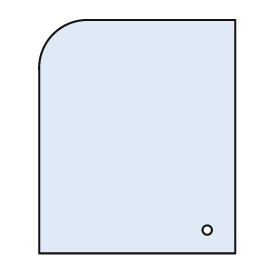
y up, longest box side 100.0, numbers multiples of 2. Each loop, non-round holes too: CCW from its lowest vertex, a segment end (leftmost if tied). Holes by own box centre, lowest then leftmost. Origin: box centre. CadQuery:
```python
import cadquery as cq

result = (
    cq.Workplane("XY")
    .moveTo(-42.0, -50.0)
    .lineTo(42.0, -50.0)
    .lineTo(42.0, 50.0)
    .lineTo(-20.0, 50.0)
    .threePointArc((-36.0, 44.0), (-42.0, 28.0))
    .close()
    .moveTo(30.0, -40.0)
    .circle(2.0)
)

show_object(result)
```